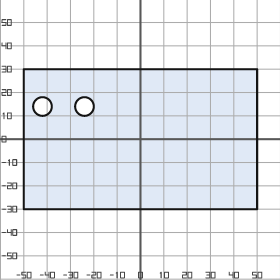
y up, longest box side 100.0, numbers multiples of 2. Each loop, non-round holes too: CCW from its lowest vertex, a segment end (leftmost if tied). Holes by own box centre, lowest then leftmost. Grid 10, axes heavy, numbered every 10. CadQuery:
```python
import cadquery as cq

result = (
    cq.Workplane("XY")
    .moveTo(-50.0, -30.0)
    .lineTo(50.0, -30.0)
    .lineTo(50.0, 30.0)
    .lineTo(-50.0, 30.0)
    .close()
    .moveTo(-42.0, 14.0)
    .circle(4.0)
    .moveTo(-24.0, 14.0)
    .circle(4.0)
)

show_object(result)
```